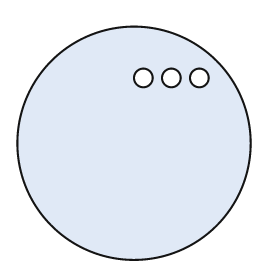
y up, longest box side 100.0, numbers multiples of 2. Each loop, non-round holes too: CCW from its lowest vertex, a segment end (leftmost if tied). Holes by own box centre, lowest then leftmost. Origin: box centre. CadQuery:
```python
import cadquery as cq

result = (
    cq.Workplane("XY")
    .moveTo(0.0, 0.0)
    .circle(50.0)
    .moveTo(4.0, 28.0)
    .circle(4.0)
    .moveTo(16.0, 28.0)
    .circle(4.0)
    .moveTo(28.0, 28.0)
    .circle(4.0)
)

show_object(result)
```